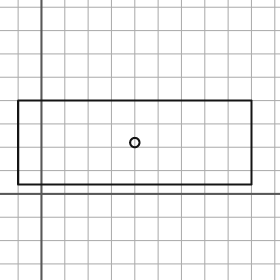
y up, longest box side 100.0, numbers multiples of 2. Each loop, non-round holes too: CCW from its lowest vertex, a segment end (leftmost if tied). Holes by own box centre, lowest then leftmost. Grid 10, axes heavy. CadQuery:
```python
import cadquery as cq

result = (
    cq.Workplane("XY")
    .moveTo(-10.0, 4.0)
    .lineTo(90.0, 4.0)
    .lineTo(90.0, 40.0)
    .lineTo(-10.0, 40.0)
    .close()
    .moveTo(40.0, 22.0)
    .circle(2.0)
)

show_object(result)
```